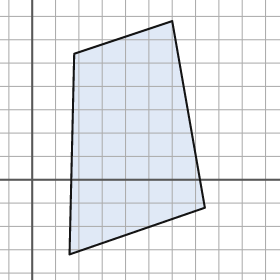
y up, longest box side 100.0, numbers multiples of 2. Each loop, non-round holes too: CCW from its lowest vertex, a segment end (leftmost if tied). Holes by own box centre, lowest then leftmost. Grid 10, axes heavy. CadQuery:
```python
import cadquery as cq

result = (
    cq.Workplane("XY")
    .moveTo(16.0, -32.0)
    .lineTo(74.0, -12.0)
    .lineTo(60.0, 68.0)
    .lineTo(18.0, 54.0)
    .close()
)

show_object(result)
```